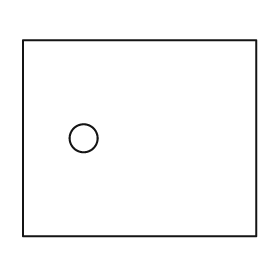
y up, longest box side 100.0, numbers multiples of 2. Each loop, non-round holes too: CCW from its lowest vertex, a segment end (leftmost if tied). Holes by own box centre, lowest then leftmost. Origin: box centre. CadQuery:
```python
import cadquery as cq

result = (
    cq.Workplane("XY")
    .moveTo(-50.0, -42.0)
    .lineTo(50.0, -42.0)
    .lineTo(50.0, 42.0)
    .lineTo(-50.0, 42.0)
    .close()
    .moveTo(-24.0, 0.0)
    .circle(6.0)
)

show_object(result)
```